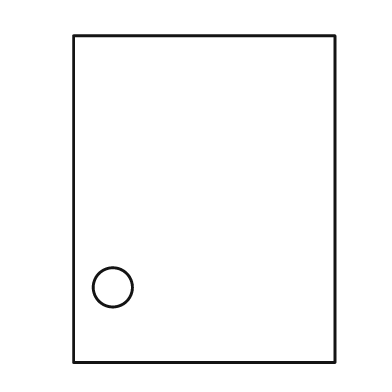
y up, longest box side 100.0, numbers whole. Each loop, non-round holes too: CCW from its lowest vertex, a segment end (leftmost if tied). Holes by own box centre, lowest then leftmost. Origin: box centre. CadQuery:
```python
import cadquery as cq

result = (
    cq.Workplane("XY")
    .moveTo(-40.0, -50.0)
    .lineTo(40.0, -50.0)
    .lineTo(40.0, 50.0)
    .lineTo(-40.0, 50.0)
    .close()
    .moveTo(-28.0, -27.0)
    .circle(6.0)
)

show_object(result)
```